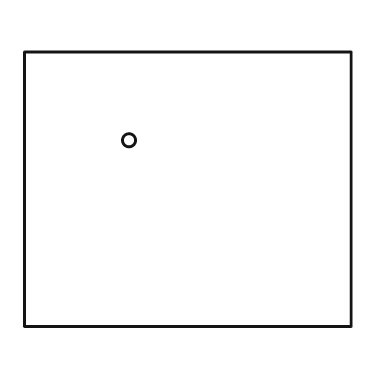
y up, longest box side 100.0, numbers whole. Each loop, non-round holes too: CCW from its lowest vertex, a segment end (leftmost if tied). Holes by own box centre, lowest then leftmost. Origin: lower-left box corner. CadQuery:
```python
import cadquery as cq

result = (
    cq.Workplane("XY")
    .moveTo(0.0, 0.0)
    .lineTo(100.0, 0.0)
    .lineTo(100.0, 84.0)
    .lineTo(0.0, 84.0)
    .close()
    .moveTo(32.0, 57.0)
    .circle(2.0)
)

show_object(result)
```